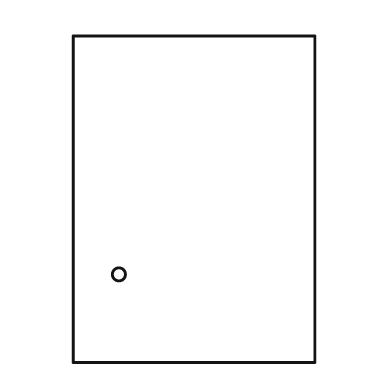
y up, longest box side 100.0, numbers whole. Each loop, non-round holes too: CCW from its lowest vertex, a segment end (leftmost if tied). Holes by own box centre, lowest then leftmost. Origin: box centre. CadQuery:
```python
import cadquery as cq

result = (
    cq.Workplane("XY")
    .moveTo(-37.0, -50.0)
    .lineTo(37.0, -50.0)
    .lineTo(37.0, 50.0)
    .lineTo(-37.0, 50.0)
    .close()
    .moveTo(-23.0, -23.0)
    .circle(2.0)
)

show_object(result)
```